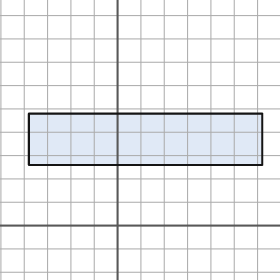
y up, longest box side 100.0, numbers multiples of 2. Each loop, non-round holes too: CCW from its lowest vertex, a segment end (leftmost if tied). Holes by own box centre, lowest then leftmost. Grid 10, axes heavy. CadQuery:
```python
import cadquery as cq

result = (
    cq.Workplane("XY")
    .moveTo(-38.0, 26.0)
    .lineTo(62.0, 26.0)
    .lineTo(62.0, 48.0)
    .lineTo(-38.0, 48.0)
    .close()
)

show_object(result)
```